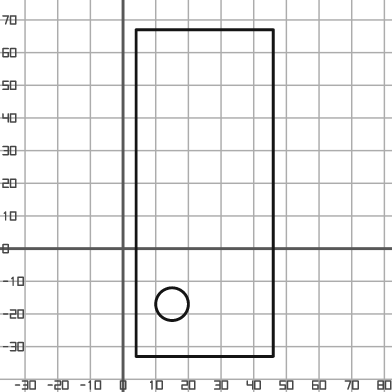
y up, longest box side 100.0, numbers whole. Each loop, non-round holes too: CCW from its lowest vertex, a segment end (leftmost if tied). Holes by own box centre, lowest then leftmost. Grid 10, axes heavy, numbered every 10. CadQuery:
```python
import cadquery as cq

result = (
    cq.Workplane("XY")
    .moveTo(4.0, -33.0)
    .lineTo(46.0, -33.0)
    .lineTo(46.0, 67.0)
    .lineTo(4.0, 67.0)
    .close()
    .moveTo(15.0, -17.0)
    .circle(5.0)
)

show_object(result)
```